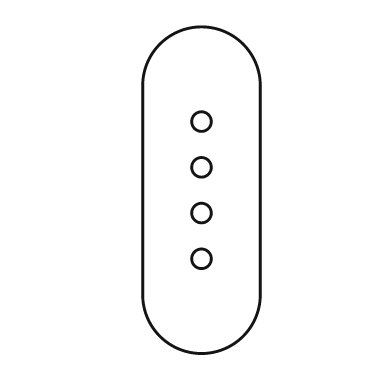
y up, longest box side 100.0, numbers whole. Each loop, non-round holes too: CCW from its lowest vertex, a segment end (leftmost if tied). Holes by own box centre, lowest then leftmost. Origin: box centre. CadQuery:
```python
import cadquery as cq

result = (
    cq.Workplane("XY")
    .moveTo(-18.0, -32.0)
    .threePointArc((0.0, -50.0), (18.0, -32.0))
    .lineTo(18.0, 32.0)
    .threePointArc((0.0, 50.0), (-18.0, 32.0))
    .close()
    .moveTo(0.0, -21.0)
    .circle(3.0)
    .moveTo(0.0, -7.0)
    .circle(3.0)
    .moveTo(0.0, 7.0)
    .circle(3.0)
    .moveTo(0.0, 21.0)
    .circle(3.0)
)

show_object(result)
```